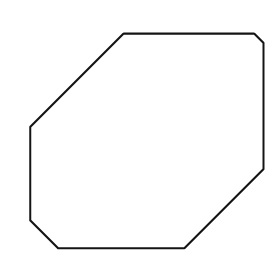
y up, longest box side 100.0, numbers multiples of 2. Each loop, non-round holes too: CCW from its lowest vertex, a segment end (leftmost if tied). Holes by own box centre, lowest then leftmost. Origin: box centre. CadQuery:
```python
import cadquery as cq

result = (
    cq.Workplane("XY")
    .moveTo(-38.0, -46.0)
    .lineTo(16.0, -46.0)
    .lineTo(50.0, -12.0)
    .lineTo(50.0, 42.0)
    .lineTo(46.0, 46.0)
    .lineTo(-10.0, 46.0)
    .lineTo(-50.0, 6.0)
    .lineTo(-50.0, -34.0)
    .close()
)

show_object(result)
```